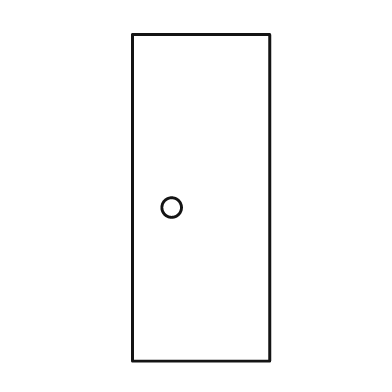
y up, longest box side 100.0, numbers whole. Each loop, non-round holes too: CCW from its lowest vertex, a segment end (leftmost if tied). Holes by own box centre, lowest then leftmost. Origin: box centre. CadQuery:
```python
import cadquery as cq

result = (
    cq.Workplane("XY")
    .moveTo(-21.0, -50.0)
    .lineTo(21.0, -50.0)
    .lineTo(21.0, 50.0)
    .lineTo(-21.0, 50.0)
    .close()
    .moveTo(-9.0, -3.0)
    .circle(3.0)
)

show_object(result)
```